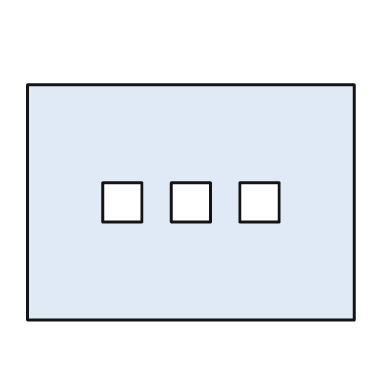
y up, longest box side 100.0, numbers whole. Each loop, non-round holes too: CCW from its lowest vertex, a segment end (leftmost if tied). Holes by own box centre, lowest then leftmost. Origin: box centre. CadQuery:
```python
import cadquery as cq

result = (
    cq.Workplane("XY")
    .moveTo(-50.0, -36.0)
    .lineTo(50.0, -36.0)
    .lineTo(50.0, 36.0)
    .lineTo(-50.0, 36.0)
    .close()
    .moveTo(-27.0, -6.0)
    .lineTo(-15.0, -6.0)
    .lineTo(-15.0, 6.0)
    .lineTo(-27.0, 6.0)
    .close()
    .moveTo(-6.0, -6.0)
    .lineTo(6.0, -6.0)
    .lineTo(6.0, 6.0)
    .lineTo(-6.0, 6.0)
    .close()
    .moveTo(15.0, -6.0)
    .lineTo(27.0, -6.0)
    .lineTo(27.0, 6.0)
    .lineTo(15.0, 6.0)
    .close()
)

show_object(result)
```